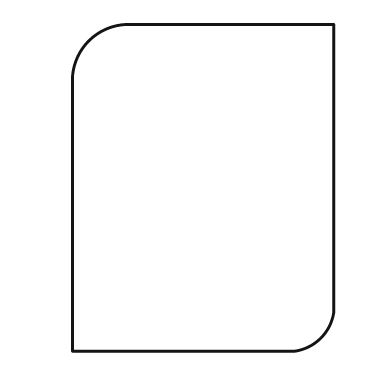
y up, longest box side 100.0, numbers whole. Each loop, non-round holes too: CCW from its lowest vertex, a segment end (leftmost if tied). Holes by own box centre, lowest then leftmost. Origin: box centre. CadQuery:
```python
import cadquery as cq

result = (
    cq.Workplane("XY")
    .moveTo(-40.0, -50.0)
    .lineTo(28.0, -50.0)
    .threePointArc((36.0, -46.0), (40.0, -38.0))
    .lineTo(40.0, 50.0)
    .lineTo(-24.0, 50.0)
    .threePointArc((-35.0, 45.0), (-40.0, 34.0))
    .close()
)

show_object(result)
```